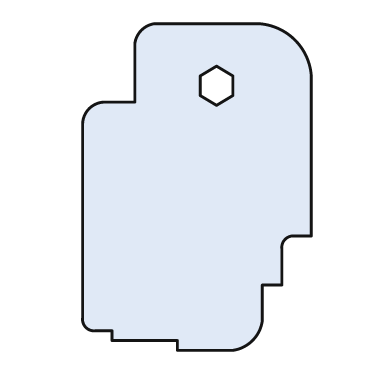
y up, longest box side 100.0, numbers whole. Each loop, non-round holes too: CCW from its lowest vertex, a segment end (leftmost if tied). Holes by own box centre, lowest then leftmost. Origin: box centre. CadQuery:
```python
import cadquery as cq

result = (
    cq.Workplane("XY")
    .moveTo(-6.0, -50.0)
    .lineTo(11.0, -50.0)
    .threePointArc((17.0, -47.0), (20.0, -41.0))
    .lineTo(20.0, -30.0)
    .lineTo(26.0, -30.0)
    .lineTo(26.0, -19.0)
    .threePointArc((27.0, -16.0), (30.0, -15.0))
    .lineTo(35.0, -15.0)
    .lineTo(35.0, 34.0)
    .threePointArc((30.0, 45.0), (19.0, 50.0))
    .lineTo(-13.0, 50.0)
    .threePointArc((-17.0, 48.0), (-19.0, 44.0))
    .lineTo(-19.0, 26.0)
    .lineTo(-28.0, 26.0)
    .threePointArc((-33.0, 24.0), (-35.0, 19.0))
    .lineTo(-35.0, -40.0)
    .threePointArc((-34.0, -43.0), (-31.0, -44.0))
    .lineTo(-26.0, -44.0)
    .lineTo(-26.0, -47.0)
    .lineTo(-6.0, -47.0)
    .close()
    .moveTo(6.0, 25.0)
    .lineTo(11.0, 28.0)
    .lineTo(11.0, 34.0)
    .lineTo(6.0, 37.0)
    .lineTo(1.0, 34.0)
    .lineTo(1.0, 28.0)
    .close()
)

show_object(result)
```